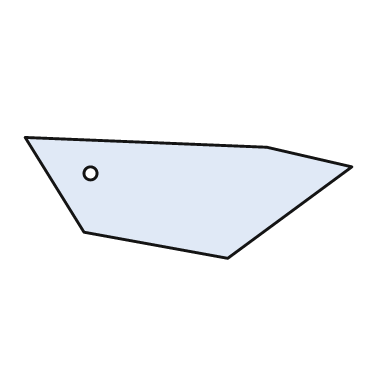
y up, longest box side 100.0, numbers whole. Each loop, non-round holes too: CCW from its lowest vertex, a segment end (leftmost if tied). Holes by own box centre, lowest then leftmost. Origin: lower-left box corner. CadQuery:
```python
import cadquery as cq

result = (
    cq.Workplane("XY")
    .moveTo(62.0, 0.0)
    .lineTo(100.0, 28.0)
    .lineTo(74.0, 34.0)
    .lineTo(0.0, 37.0)
    .lineTo(18.0, 8.0)
    .close()
    .moveTo(20.0, 26.0)
    .circle(2.0)
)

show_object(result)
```